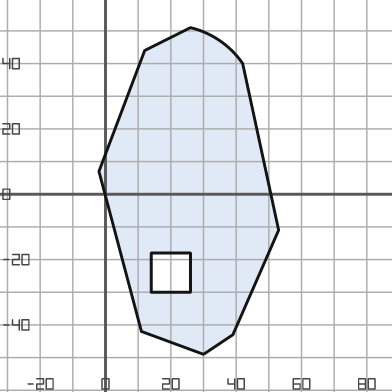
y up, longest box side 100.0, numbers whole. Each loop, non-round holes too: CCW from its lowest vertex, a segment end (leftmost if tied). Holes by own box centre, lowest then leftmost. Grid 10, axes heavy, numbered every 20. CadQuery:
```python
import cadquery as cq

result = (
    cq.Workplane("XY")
    .moveTo(30.0, -49.0)
    .lineTo(39.0, -43.0)
    .lineTo(53.0, -11.0)
    .lineTo(42.0, 40.0)
    .threePointArc((35.0, 47.0), (26.0, 51.0))
    .lineTo(12.0, 44.0)
    .lineTo(-2.0, 7.0)
    .lineTo(11.0, -42.0)
    .close()
    .moveTo(14.0, -30.0)
    .lineTo(26.0, -30.0)
    .lineTo(26.0, -18.0)
    .lineTo(14.0, -18.0)
    .close()
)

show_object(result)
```